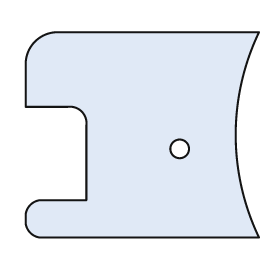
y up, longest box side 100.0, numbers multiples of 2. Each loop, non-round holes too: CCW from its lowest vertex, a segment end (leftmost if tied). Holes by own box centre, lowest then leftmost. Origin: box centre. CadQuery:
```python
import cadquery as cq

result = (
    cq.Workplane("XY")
    .moveTo(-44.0, -44.0)
    .lineTo(50.0, -44.0)
    .threePointArc((40.0, 0.0), (50.0, 44.0))
    .lineTo(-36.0, 44.0)
    .threePointArc((-46.0, 40.0), (-50.0, 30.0))
    .lineTo(-50.0, 12.0)
    .lineTo(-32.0, 12.0)
    .threePointArc((-26.0, 10.0), (-24.0, 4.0))
    .lineTo(-24.0, -28.0)
    .lineTo(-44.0, -28.0)
    .threePointArc((-48.0, -30.0), (-50.0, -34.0))
    .lineTo(-50.0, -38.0)
    .threePointArc((-48.0, -42.0), (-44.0, -44.0))
    .close()
    .moveTo(16.0, -6.0)
    .circle(4.0)
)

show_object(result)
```